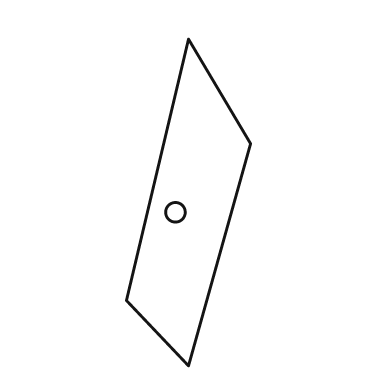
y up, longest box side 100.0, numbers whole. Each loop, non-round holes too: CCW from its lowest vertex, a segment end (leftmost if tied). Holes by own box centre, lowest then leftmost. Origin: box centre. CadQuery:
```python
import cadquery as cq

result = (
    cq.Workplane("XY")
    .moveTo(0.0, -50.0)
    .lineTo(19.0, 18.0)
    .lineTo(0.0, 50.0)
    .lineTo(-19.0, -30.0)
    .close()
    .moveTo(-4.0, -3.0)
    .circle(3.0)
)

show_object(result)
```